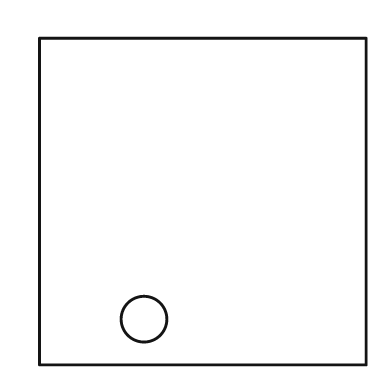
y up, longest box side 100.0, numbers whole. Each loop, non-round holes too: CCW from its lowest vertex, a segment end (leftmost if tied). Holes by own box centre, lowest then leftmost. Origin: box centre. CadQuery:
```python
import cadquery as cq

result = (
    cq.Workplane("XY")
    .moveTo(-50.0, -50.0)
    .lineTo(50.0, -50.0)
    .lineTo(50.0, 50.0)
    .lineTo(-50.0, 50.0)
    .close()
    .moveTo(-18.0, -36.0)
    .circle(7.0)
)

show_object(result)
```